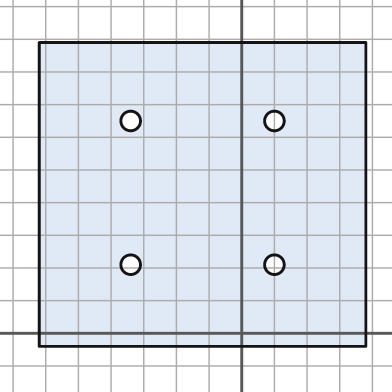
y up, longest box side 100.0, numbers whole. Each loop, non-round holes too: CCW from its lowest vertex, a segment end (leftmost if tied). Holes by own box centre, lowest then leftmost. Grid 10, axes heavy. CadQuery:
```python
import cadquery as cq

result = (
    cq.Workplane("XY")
    .moveTo(-62.0, -4.0)
    .lineTo(38.0, -4.0)
    .lineTo(38.0, 89.0)
    .lineTo(-62.0, 89.0)
    .close()
    .moveTo(-34.0, 21.0)
    .circle(3.0)
    .moveTo(10.0, 21.0)
    .circle(3.0)
    .moveTo(-34.0, 65.0)
    .circle(3.0)
    .moveTo(10.0, 65.0)
    .circle(3.0)
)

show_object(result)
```